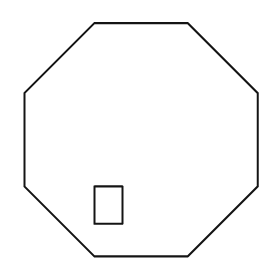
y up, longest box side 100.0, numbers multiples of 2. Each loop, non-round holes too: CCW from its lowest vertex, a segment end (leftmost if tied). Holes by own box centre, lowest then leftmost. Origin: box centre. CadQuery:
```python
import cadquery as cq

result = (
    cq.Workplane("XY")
    .moveTo(-20.0, -50.0)
    .lineTo(20.0, -50.0)
    .lineTo(50.0, -20.0)
    .lineTo(50.0, 20.0)
    .lineTo(20.0, 50.0)
    .lineTo(-20.0, 50.0)
    .lineTo(-50.0, 20.0)
    .lineTo(-50.0, -20.0)
    .close()
    .moveTo(-20.0, -36.0)
    .lineTo(-8.0, -36.0)
    .lineTo(-8.0, -20.0)
    .lineTo(-20.0, -20.0)
    .close()
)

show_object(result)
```